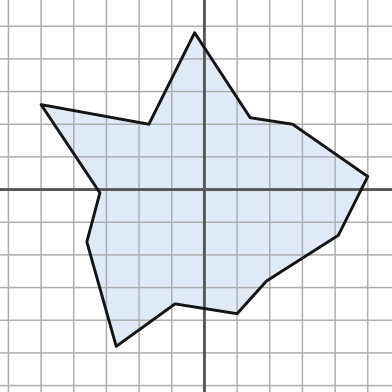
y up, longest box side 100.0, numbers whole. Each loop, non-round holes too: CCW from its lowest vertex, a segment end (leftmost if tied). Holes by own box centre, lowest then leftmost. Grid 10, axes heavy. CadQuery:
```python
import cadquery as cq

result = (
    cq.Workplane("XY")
    .moveTo(-27.0, -48.0)
    .lineTo(-9.0, -35.0)
    .lineTo(10.0, -38.0)
    .lineTo(19.0, -28.0)
    .lineTo(41.0, -14.0)
    .lineTo(50.0, 4.0)
    .lineTo(27.0, 20.0)
    .lineTo(14.0, 22.0)
    .lineTo(-3.0, 48.0)
    .lineTo(-17.0, 20.0)
    .lineTo(-50.0, 26.0)
    .lineTo(-32.0, -1.0)
    .lineTo(-36.0, -16.0)
    .close()
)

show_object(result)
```